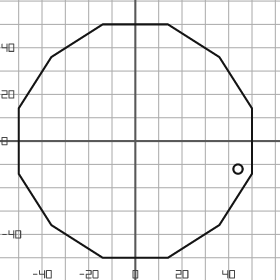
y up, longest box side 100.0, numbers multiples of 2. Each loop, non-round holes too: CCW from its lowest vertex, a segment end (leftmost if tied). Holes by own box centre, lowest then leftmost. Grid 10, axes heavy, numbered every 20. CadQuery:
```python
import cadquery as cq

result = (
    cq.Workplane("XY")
    .moveTo(-14.0, -50.0)
    .lineTo(14.0, -50.0)
    .lineTo(36.0, -36.0)
    .lineTo(50.0, -14.0)
    .lineTo(50.0, 14.0)
    .lineTo(36.0, 36.0)
    .lineTo(14.0, 50.0)
    .lineTo(-14.0, 50.0)
    .lineTo(-36.0, 36.0)
    .lineTo(-50.0, 14.0)
    .lineTo(-50.0, -14.0)
    .lineTo(-36.0, -36.0)
    .close()
    .moveTo(44.0, -12.0)
    .circle(2.0)
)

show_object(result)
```